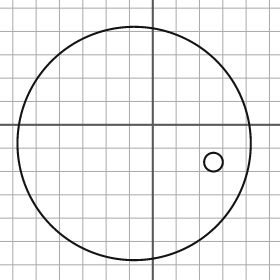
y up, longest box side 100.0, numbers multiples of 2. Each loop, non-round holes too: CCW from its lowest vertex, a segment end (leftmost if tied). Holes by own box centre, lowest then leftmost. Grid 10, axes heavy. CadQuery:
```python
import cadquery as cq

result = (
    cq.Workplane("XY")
    .moveTo(-8.0, -8.0)
    .circle(50.0)
    .moveTo(26.0, -16.0)
    .circle(4.0)
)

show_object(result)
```